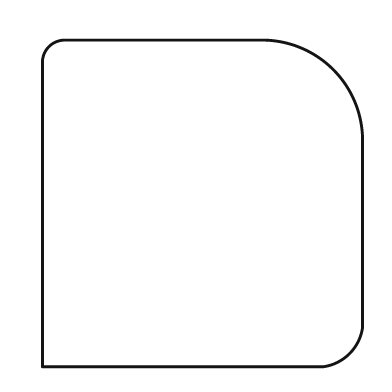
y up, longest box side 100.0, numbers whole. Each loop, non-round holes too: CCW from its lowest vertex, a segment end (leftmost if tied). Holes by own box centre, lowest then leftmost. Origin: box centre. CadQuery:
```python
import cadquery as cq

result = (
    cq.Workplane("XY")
    .moveTo(-49.0, -50.0)
    .lineTo(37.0, -50.0)
    .threePointArc((45.0, -46.0), (49.0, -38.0))
    .lineTo(49.0, 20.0)
    .threePointArc((40.0, 41.0), (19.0, 50.0))
    .lineTo(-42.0, 50.0)
    .threePointArc((-47.0, 48.0), (-49.0, 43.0))
    .close()
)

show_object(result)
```